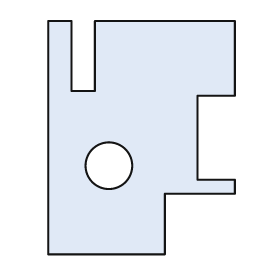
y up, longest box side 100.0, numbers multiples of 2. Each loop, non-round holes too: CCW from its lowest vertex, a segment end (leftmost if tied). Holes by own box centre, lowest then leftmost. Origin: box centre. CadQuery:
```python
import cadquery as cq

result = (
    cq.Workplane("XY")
    .moveTo(-40.0, -50.0)
    .lineTo(10.0, -50.0)
    .lineTo(10.0, -24.0)
    .lineTo(40.0, -24.0)
    .lineTo(40.0, -18.0)
    .lineTo(24.0, -18.0)
    .lineTo(24.0, 18.0)
    .lineTo(40.0, 18.0)
    .lineTo(40.0, 50.0)
    .lineTo(-20.0, 50.0)
    .lineTo(-20.0, 20.0)
    .lineTo(-30.0, 20.0)
    .lineTo(-30.0, 50.0)
    .lineTo(-40.0, 50.0)
    .close()
    .moveTo(-14.0, -12.0)
    .circle(10.0)
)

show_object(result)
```